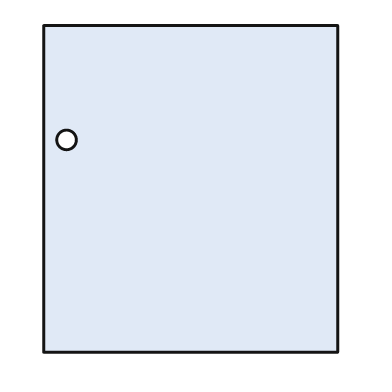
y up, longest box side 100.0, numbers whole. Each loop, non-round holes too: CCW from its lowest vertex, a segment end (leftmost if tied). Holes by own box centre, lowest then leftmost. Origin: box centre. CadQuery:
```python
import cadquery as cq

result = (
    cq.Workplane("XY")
    .moveTo(-45.0, -50.0)
    .lineTo(45.0, -50.0)
    .lineTo(45.0, 50.0)
    .lineTo(-45.0, 50.0)
    .close()
    .moveTo(-38.0, 15.0)
    .circle(3.0)
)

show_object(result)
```